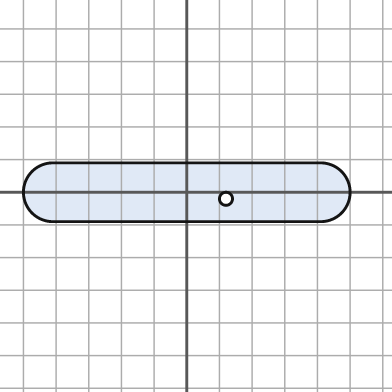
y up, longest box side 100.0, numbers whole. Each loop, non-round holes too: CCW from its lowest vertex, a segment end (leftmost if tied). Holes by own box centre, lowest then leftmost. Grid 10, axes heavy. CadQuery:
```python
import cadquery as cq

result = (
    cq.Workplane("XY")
    .moveTo(-41.0, -9.0)
    .lineTo(41.0, -9.0)
    .threePointArc((50.0, 0.0), (41.0, 9.0))
    .lineTo(-41.0, 9.0)
    .threePointArc((-50.0, 0.0), (-41.0, -9.0))
    .close()
    .moveTo(12.0, -2.0)
    .circle(2.0)
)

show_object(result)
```